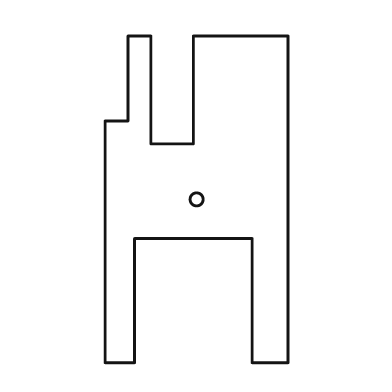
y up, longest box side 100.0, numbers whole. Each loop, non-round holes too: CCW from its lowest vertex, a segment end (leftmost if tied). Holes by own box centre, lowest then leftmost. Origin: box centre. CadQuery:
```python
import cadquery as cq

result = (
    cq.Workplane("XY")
    .moveTo(-28.0, -50.0)
    .lineTo(-19.0, -50.0)
    .lineTo(-19.0, -12.0)
    .lineTo(17.0, -12.0)
    .lineTo(17.0, -50.0)
    .lineTo(28.0, -50.0)
    .lineTo(28.0, 50.0)
    .lineTo(-1.0, 50.0)
    .lineTo(-1.0, 17.0)
    .lineTo(-14.0, 17.0)
    .lineTo(-14.0, 50.0)
    .lineTo(-21.0, 50.0)
    .lineTo(-21.0, 24.0)
    .lineTo(-28.0, 24.0)
    .close()
    .moveTo(0.0, 0.0)
    .circle(2.0)
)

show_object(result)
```